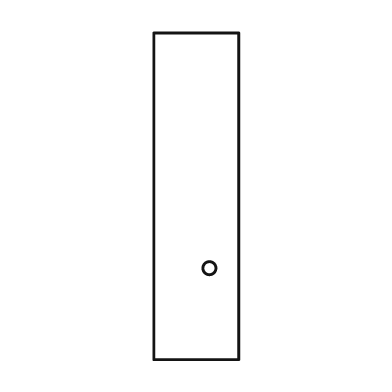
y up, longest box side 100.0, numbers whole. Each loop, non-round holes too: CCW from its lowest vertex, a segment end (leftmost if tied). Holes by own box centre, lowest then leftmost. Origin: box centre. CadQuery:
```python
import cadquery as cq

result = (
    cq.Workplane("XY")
    .moveTo(-13.0, -50.0)
    .lineTo(13.0, -50.0)
    .lineTo(13.0, 50.0)
    .lineTo(-13.0, 50.0)
    .close()
    .moveTo(4.0, -22.0)
    .circle(2.0)
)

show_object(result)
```